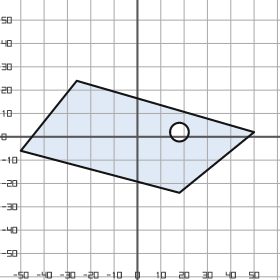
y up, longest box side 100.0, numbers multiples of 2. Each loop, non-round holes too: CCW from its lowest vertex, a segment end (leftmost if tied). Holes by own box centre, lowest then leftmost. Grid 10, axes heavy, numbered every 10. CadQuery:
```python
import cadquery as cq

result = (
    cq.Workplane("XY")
    .moveTo(18.0, -24.0)
    .lineTo(50.0, 2.0)
    .lineTo(-26.0, 24.0)
    .lineTo(-50.0, -6.0)
    .close()
    .moveTo(18.0, 2.0)
    .circle(4.0)
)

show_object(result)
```